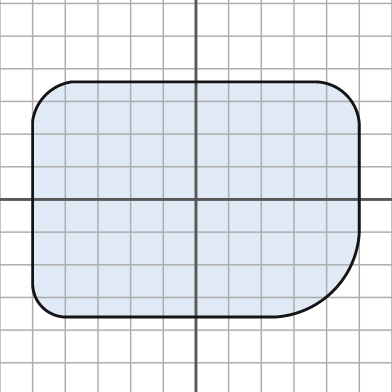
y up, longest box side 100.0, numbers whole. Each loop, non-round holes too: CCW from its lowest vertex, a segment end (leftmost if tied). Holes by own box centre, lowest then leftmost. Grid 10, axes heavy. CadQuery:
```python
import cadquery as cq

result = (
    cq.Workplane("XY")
    .moveTo(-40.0, -36.0)
    .lineTo(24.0, -36.0)
    .threePointArc((42.0, -28.0), (50.0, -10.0))
    .lineTo(50.0, 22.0)
    .threePointArc((46.0, 32.0), (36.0, 36.0))
    .lineTo(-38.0, 36.0)
    .threePointArc((-46.0, 32.0), (-50.0, 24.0))
    .lineTo(-50.0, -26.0)
    .threePointArc((-47.0, -33.0), (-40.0, -36.0))
    .close()
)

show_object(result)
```